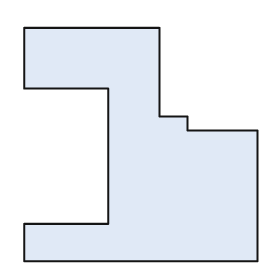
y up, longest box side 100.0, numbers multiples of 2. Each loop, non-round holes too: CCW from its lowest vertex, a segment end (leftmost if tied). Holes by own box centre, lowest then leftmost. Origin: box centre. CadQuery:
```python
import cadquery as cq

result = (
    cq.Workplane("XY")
    .moveTo(-50.0, -50.0)
    .lineTo(50.0, -50.0)
    .lineTo(50.0, 6.0)
    .lineTo(20.0, 6.0)
    .lineTo(20.0, 12.0)
    .lineTo(8.0, 12.0)
    .lineTo(8.0, 50.0)
    .lineTo(-50.0, 50.0)
    .lineTo(-50.0, 24.0)
    .lineTo(-14.0, 24.0)
    .lineTo(-14.0, -34.0)
    .lineTo(-50.0, -34.0)
    .close()
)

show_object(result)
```